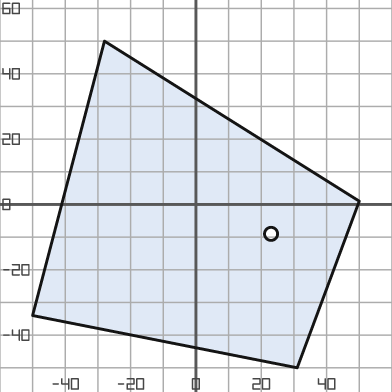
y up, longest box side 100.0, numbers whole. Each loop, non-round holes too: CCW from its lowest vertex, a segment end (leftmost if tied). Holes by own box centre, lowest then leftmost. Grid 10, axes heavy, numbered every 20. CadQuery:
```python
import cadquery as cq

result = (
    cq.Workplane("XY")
    .moveTo(31.0, -50.0)
    .lineTo(50.0, 1.0)
    .lineTo(-28.0, 50.0)
    .lineTo(-50.0, -34.0)
    .close()
    .moveTo(23.0, -9.0)
    .circle(2.0)
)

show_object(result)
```